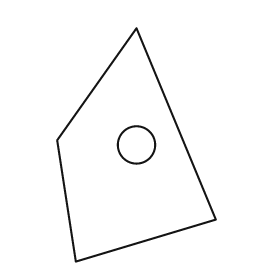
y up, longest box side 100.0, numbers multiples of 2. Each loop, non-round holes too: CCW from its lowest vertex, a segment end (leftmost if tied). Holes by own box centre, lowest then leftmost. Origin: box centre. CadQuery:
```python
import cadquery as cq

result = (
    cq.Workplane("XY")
    .moveTo(-26.0, -50.0)
    .lineTo(34.0, -32.0)
    .lineTo(0.0, 50.0)
    .lineTo(-34.0, 2.0)
    .close()
    .moveTo(0.0, 0.0)
    .circle(8.0)
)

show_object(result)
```